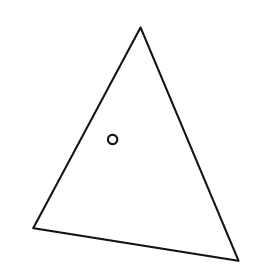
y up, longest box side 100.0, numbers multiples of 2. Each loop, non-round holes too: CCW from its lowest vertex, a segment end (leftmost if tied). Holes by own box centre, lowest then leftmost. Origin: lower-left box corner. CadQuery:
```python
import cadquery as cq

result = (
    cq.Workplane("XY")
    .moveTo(88.0, 0.0)
    .lineTo(46.0, 100.0)
    .lineTo(0.0, 14.0)
    .close()
    .moveTo(34.0, 52.0)
    .circle(2.0)
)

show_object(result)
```